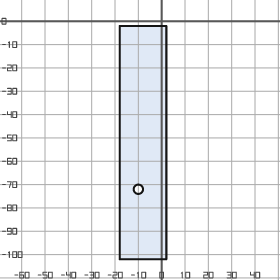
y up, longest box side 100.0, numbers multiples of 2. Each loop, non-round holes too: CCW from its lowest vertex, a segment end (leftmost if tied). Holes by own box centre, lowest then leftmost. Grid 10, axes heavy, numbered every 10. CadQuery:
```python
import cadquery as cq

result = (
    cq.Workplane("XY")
    .moveTo(-18.0, -102.0)
    .lineTo(2.0, -102.0)
    .lineTo(2.0, -2.0)
    .lineTo(-18.0, -2.0)
    .close()
    .moveTo(-10.0, -72.0)
    .circle(2.0)
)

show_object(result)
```